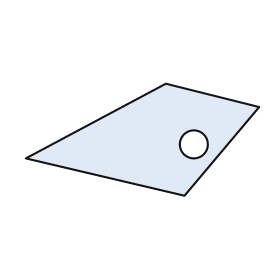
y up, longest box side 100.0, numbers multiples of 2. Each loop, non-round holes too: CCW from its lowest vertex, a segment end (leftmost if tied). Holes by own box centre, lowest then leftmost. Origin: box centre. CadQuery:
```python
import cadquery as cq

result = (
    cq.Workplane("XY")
    .moveTo(18.0, -24.0)
    .lineTo(50.0, 14.0)
    .lineTo(10.0, 24.0)
    .lineTo(-50.0, -8.0)
    .close()
    .moveTo(22.0, -2.0)
    .circle(6.0)
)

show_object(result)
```